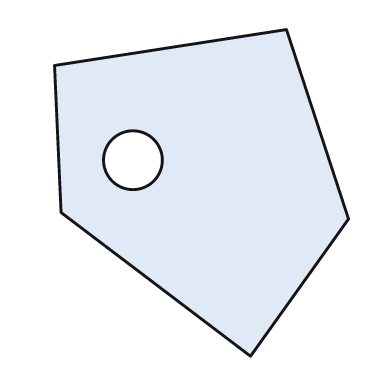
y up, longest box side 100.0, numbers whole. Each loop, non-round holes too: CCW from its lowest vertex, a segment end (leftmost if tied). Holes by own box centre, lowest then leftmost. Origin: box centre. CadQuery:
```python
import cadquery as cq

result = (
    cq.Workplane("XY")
    .moveTo(15.0, -50.0)
    .lineTo(45.0, -8.0)
    .lineTo(26.0, 50.0)
    .lineTo(-45.0, 39.0)
    .lineTo(-43.0, -6.0)
    .close()
    .moveTo(-21.0, 10.0)
    .circle(9.0)
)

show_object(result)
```